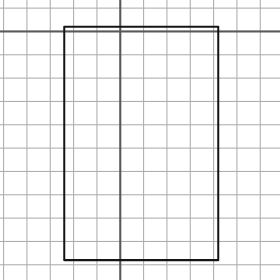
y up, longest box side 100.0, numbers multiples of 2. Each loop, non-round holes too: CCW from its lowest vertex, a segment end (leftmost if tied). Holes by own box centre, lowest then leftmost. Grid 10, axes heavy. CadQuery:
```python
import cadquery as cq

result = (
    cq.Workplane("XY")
    .moveTo(-24.0, -98.0)
    .lineTo(42.0, -98.0)
    .lineTo(42.0, 2.0)
    .lineTo(-24.0, 2.0)
    .close()
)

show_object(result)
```